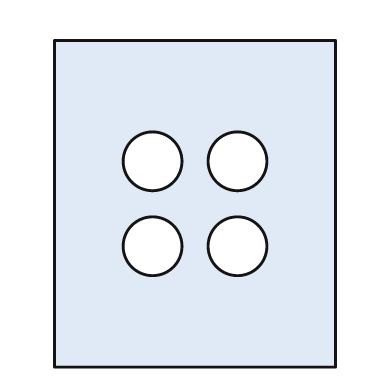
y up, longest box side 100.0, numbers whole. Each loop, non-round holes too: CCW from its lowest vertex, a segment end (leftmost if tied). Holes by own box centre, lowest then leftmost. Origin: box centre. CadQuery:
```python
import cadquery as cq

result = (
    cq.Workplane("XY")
    .moveTo(-43.0, -50.0)
    .lineTo(43.0, -50.0)
    .lineTo(43.0, 50.0)
    .lineTo(-43.0, 50.0)
    .close()
    .moveTo(-13.0, -13.0)
    .circle(9.0)
    .moveTo(13.0, -13.0)
    .circle(9.0)
    .moveTo(-13.0, 13.0)
    .circle(9.0)
    .moveTo(13.0, 13.0)
    .circle(9.0)
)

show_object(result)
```